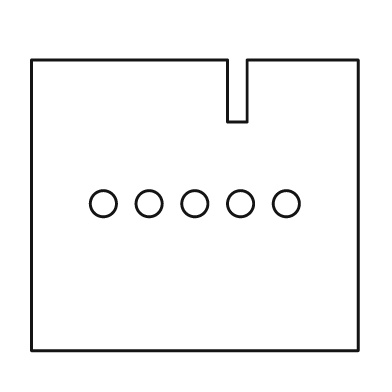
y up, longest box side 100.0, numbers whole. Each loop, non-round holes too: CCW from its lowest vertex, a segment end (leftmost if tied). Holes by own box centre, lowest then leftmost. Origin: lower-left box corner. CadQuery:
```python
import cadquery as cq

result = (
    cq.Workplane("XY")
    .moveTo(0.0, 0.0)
    .lineTo(100.0, 0.0)
    .lineTo(100.0, 89.0)
    .lineTo(66.0, 89.0)
    .lineTo(66.0, 70.0)
    .lineTo(60.0, 70.0)
    .lineTo(60.0, 89.0)
    .lineTo(0.0, 89.0)
    .close()
    .moveTo(22.0, 45.0)
    .circle(4.0)
    .moveTo(36.0, 45.0)
    .circle(4.0)
    .moveTo(50.0, 45.0)
    .circle(4.0)
    .moveTo(64.0, 45.0)
    .circle(4.0)
    .moveTo(78.0, 45.0)
    .circle(4.0)
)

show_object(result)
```